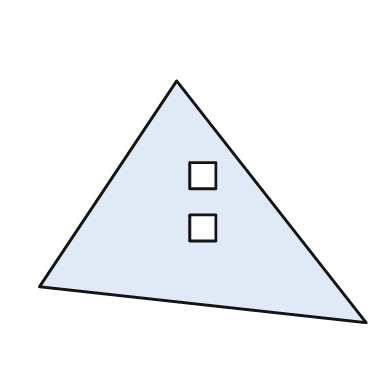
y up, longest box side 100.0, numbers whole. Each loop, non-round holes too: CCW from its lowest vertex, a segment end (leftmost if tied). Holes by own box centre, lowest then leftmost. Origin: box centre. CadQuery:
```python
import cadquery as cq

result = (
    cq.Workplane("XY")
    .moveTo(50.0, -37.0)
    .lineTo(-8.0, 37.0)
    .lineTo(-50.0, -26.0)
    .close()
    .moveTo(-4.0, -12.0)
    .lineTo(4.0, -12.0)
    .lineTo(4.0, -4.0)
    .lineTo(-4.0, -4.0)
    .close()
    .moveTo(-4.0, 4.0)
    .lineTo(4.0, 4.0)
    .lineTo(4.0, 12.0)
    .lineTo(-4.0, 12.0)
    .close()
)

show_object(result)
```